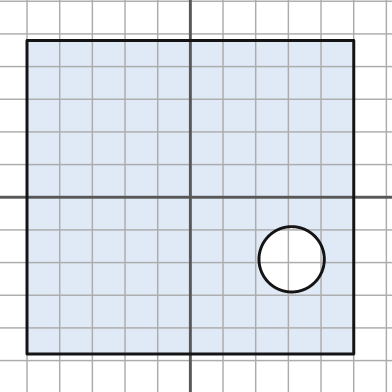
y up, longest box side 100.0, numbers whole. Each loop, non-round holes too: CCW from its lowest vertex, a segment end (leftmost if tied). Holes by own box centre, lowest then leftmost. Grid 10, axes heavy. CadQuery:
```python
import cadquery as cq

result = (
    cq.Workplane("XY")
    .moveTo(-50.0, -48.0)
    .lineTo(50.0, -48.0)
    .lineTo(50.0, 48.0)
    .lineTo(-50.0, 48.0)
    .close()
    .moveTo(31.0, -19.0)
    .circle(10.0)
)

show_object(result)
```